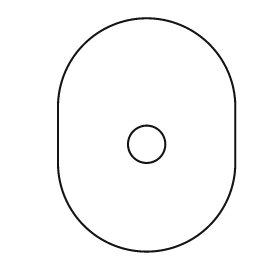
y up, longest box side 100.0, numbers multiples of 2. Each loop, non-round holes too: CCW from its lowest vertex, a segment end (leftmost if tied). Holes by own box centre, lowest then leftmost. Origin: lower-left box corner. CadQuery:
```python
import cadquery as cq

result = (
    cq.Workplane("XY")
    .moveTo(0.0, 38.0)
    .threePointArc((38.0, 0.0), (76.0, 38.0))
    .lineTo(76.0, 62.0)
    .threePointArc((38.0, 100.0), (0.0, 62.0))
    .close()
    .moveTo(38.0, 46.0)
    .circle(8.0)
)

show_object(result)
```